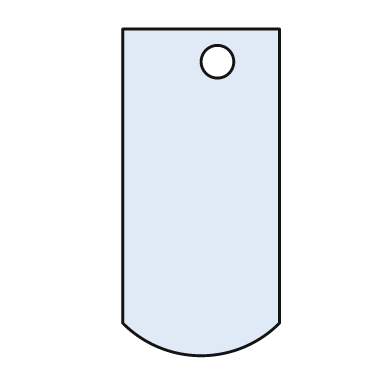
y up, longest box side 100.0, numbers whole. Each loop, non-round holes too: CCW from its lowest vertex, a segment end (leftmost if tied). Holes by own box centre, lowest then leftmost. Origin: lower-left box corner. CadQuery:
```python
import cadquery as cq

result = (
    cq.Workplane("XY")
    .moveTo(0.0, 10.0)
    .threePointArc((24.0, 0.0), (48.0, 10.0))
    .lineTo(48.0, 100.0)
    .lineTo(0.0, 100.0)
    .close()
    .moveTo(29.0, 90.0)
    .circle(5.0)
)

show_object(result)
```